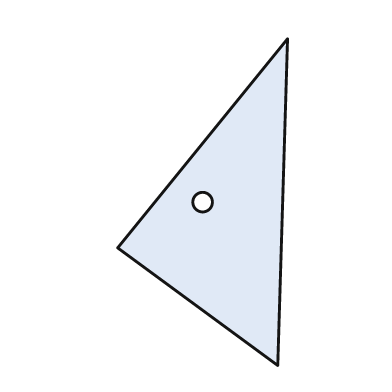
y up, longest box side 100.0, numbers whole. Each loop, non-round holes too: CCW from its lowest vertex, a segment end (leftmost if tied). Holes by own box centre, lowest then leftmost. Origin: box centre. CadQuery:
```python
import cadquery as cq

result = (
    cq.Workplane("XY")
    .moveTo(23.0, -50.0)
    .lineTo(26.0, 50.0)
    .lineTo(-26.0, -14.0)
    .close()
    .moveTo(0.0, 0.0)
    .circle(3.0)
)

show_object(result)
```